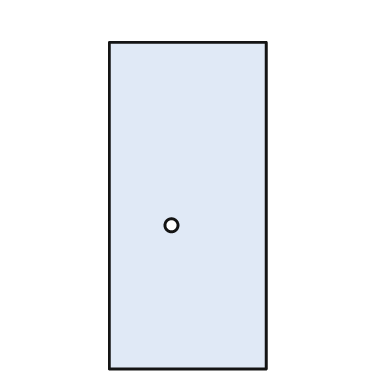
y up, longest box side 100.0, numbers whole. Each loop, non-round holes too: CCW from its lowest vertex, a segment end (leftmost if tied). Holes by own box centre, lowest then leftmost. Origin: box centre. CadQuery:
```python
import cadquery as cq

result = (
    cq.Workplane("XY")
    .moveTo(-24.0, -50.0)
    .lineTo(24.0, -50.0)
    .lineTo(24.0, 50.0)
    .lineTo(-24.0, 50.0)
    .close()
    .moveTo(-5.0, -6.0)
    .circle(2.0)
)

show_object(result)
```